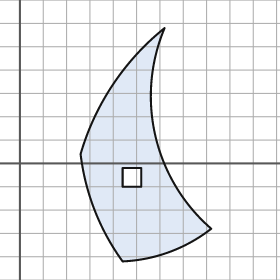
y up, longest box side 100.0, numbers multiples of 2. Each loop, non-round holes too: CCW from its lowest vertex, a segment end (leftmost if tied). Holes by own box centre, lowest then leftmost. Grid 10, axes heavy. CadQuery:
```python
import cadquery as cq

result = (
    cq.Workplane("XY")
    .moveTo(44.0, -42.0)
    .threePointArc((64.0, -38.0), (82.0, -28.0))
    .threePointArc((58.0, 12.0), (62.0, 58.0))
    .threePointArc((40.0, 34.0), (26.0, 4.0))
    .threePointArc((32.0, -20.0), (44.0, -42.0))
    .close()
    .moveTo(44.0, -10.0)
    .lineTo(52.0, -10.0)
    .lineTo(52.0, -2.0)
    .lineTo(44.0, -2.0)
    .close()
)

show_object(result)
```